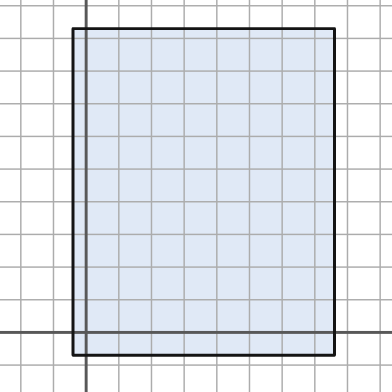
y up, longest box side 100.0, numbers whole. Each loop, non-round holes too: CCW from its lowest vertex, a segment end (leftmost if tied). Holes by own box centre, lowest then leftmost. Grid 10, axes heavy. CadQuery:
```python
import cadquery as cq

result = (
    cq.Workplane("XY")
    .moveTo(-4.0, -7.0)
    .lineTo(76.0, -7.0)
    .lineTo(76.0, 93.0)
    .lineTo(-4.0, 93.0)
    .close()
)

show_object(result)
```